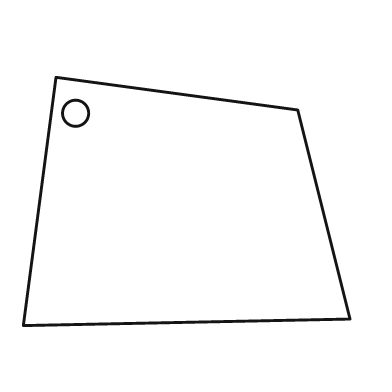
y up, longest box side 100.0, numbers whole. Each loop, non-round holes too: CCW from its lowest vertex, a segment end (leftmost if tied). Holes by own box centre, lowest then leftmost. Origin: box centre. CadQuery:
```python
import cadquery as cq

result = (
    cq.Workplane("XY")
    .moveTo(-50.0, -38.0)
    .lineTo(50.0, -36.0)
    .lineTo(34.0, 28.0)
    .lineTo(-40.0, 38.0)
    .close()
    .moveTo(-34.0, 27.0)
    .circle(4.0)
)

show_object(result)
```